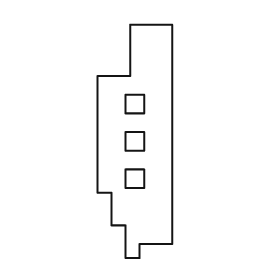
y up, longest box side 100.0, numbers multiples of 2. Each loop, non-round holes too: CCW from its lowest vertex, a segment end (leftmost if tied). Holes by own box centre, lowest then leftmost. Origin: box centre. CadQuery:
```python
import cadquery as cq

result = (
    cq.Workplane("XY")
    .moveTo(-4.0, -50.0)
    .lineTo(2.0, -50.0)
    .lineTo(2.0, -44.0)
    .lineTo(16.0, -44.0)
    .lineTo(16.0, 50.0)
    .lineTo(-2.0, 50.0)
    .lineTo(-2.0, 28.0)
    .lineTo(-16.0, 28.0)
    .lineTo(-16.0, -22.0)
    .lineTo(-10.0, -22.0)
    .lineTo(-10.0, -36.0)
    .lineTo(-4.0, -36.0)
    .close()
    .moveTo(-4.0, -20.0)
    .lineTo(4.0, -20.0)
    .lineTo(4.0, -12.0)
    .lineTo(-4.0, -12.0)
    .close()
    .moveTo(-4.0, -4.0)
    .lineTo(4.0, -4.0)
    .lineTo(4.0, 4.0)
    .lineTo(-4.0, 4.0)
    .close()
    .moveTo(-4.0, 12.0)
    .lineTo(4.0, 12.0)
    .lineTo(4.0, 20.0)
    .lineTo(-4.0, 20.0)
    .close()
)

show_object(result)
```